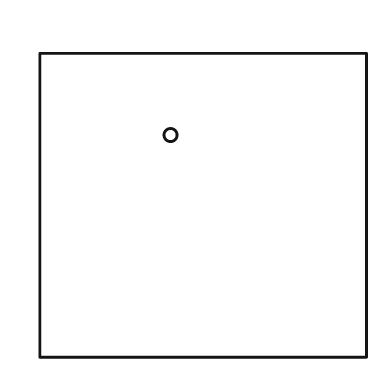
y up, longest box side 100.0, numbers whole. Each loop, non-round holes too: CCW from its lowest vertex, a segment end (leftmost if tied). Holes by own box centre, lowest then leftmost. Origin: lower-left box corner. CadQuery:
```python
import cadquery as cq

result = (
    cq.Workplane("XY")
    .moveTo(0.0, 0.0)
    .lineTo(100.0, 0.0)
    .lineTo(100.0, 93.0)
    .lineTo(0.0, 93.0)
    .close()
    .moveTo(40.0, 68.0)
    .circle(2.0)
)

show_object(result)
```